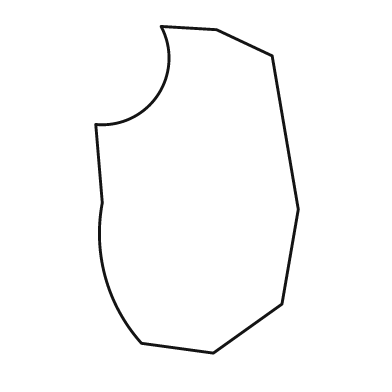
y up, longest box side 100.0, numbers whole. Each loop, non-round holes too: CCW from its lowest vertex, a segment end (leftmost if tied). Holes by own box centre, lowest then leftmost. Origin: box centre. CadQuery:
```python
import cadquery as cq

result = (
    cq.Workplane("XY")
    .moveTo(5.0, -50.0)
    .lineTo(26.0, -35.0)
    .lineTo(31.0, -6.0)
    .lineTo(23.0, 41.0)
    .lineTo(6.0, 49.0)
    .lineTo(-11.0, 50.0)
    .threePointArc((-12.0, 29.0), (-31.0, 20.0))
    .lineTo(-29.0, -4.0)
    .threePointArc((-28.0, -27.0), (-17.0, -47.0))
    .close()
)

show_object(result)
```